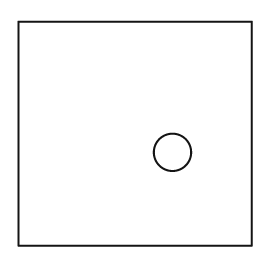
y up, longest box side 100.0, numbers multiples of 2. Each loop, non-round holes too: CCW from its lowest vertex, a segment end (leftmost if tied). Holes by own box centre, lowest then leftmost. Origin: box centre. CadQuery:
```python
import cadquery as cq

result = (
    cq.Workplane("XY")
    .moveTo(-50.0, -48.0)
    .lineTo(50.0, -48.0)
    .lineTo(50.0, 48.0)
    .lineTo(-50.0, 48.0)
    .close()
    .moveTo(16.0, -8.0)
    .circle(8.0)
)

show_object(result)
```